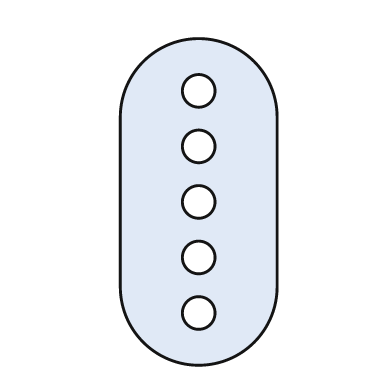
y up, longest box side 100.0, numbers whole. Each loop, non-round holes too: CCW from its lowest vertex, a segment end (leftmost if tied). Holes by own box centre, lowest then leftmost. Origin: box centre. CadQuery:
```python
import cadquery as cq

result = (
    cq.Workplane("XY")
    .moveTo(-24.0, -26.0)
    .threePointArc((0.0, -50.0), (24.0, -26.0))
    .lineTo(24.0, 26.0)
    .threePointArc((0.0, 50.0), (-24.0, 26.0))
    .close()
    .moveTo(0.0, -34.0)
    .circle(5.0)
    .moveTo(0.0, -17.0)
    .circle(5.0)
    .moveTo(0.0, 0.0)
    .circle(5.0)
    .moveTo(0.0, 17.0)
    .circle(5.0)
    .moveTo(0.0, 34.0)
    .circle(5.0)
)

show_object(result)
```